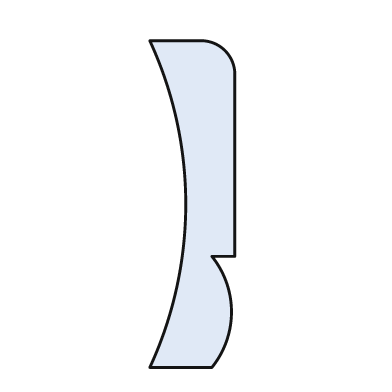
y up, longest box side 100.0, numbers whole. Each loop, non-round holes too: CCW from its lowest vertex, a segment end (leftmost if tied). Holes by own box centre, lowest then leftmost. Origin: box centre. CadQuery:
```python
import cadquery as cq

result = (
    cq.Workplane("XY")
    .moveTo(-13.0, -50.0)
    .lineTo(6.0, -50.0)
    .threePointArc((12.0, -33.0), (6.0, -16.0))
    .lineTo(13.0, -16.0)
    .lineTo(13.0, 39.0)
    .threePointArc((10.0, 47.0), (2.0, 50.0))
    .lineTo(-13.0, 50.0)
    .threePointArc((-2.0, 0.0), (-13.0, -50.0))
    .close()
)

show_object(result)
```